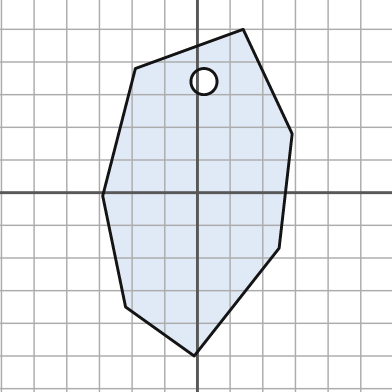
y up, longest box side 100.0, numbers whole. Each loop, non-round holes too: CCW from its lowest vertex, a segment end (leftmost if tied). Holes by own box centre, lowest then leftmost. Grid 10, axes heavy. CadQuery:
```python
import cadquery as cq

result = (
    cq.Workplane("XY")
    .moveTo(-1.0, -50.0)
    .lineTo(25.0, -17.0)
    .lineTo(29.0, 18.0)
    .lineTo(14.0, 50.0)
    .lineTo(-19.0, 38.0)
    .lineTo(-29.0, -1.0)
    .lineTo(-22.0, -35.0)
    .close()
    .moveTo(2.0, 34.0)
    .circle(4.0)
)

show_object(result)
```